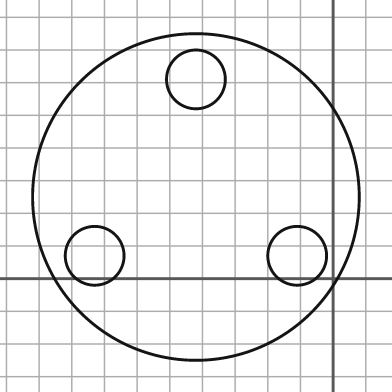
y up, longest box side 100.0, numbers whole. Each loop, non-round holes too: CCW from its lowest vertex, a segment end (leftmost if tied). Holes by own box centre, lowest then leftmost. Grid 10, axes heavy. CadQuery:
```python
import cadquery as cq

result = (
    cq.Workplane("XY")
    .moveTo(-42.0, 25.0)
    .circle(50.0)
    .moveTo(-73.0, 7.0)
    .circle(9.0)
    .moveTo(-11.0, 7.0)
    .circle(9.0)
    .moveTo(-42.0, 61.0)
    .circle(9.0)
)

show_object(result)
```